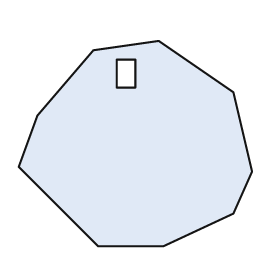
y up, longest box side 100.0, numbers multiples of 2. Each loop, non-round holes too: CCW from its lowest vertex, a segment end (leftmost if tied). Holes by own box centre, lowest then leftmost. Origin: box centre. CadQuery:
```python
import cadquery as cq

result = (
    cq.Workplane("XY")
    .moveTo(-16.0, -44.0)
    .lineTo(12.0, -44.0)
    .lineTo(42.0, -30.0)
    .lineTo(50.0, -12.0)
    .lineTo(42.0, 22.0)
    .lineTo(10.0, 44.0)
    .lineTo(-18.0, 40.0)
    .lineTo(-42.0, 12.0)
    .lineTo(-50.0, -10.0)
    .close()
    .moveTo(-8.0, 24.0)
    .lineTo(0.0, 24.0)
    .lineTo(0.0, 36.0)
    .lineTo(-8.0, 36.0)
    .close()
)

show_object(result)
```